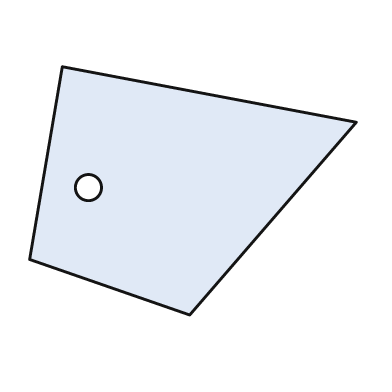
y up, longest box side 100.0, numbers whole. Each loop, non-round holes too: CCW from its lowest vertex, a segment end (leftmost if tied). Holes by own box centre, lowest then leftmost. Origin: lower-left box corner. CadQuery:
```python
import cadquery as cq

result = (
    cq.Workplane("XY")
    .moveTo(49.0, 0.0)
    .lineTo(100.0, 59.0)
    .lineTo(10.0, 76.0)
    .lineTo(0.0, 17.0)
    .close()
    .moveTo(18.0, 39.0)
    .circle(4.0)
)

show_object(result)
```